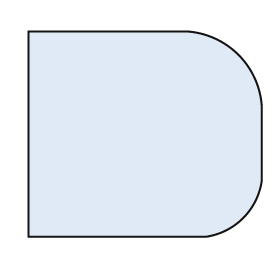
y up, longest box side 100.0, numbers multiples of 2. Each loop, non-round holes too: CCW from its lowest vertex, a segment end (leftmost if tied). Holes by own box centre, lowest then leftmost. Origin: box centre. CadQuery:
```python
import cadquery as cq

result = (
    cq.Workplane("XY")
    .moveTo(-50.0, -44.0)
    .lineTo(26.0, -44.0)
    .threePointArc((42.0, -36.0), (50.0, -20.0))
    .lineTo(50.0, 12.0)
    .threePointArc((40.0, 34.0), (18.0, 44.0))
    .lineTo(-50.0, 44.0)
    .close()
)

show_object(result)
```